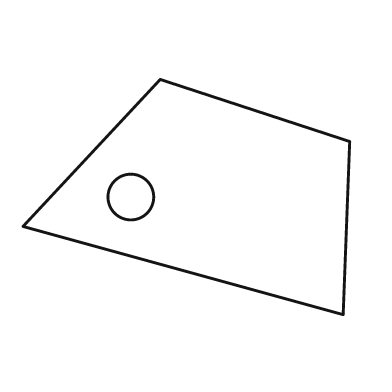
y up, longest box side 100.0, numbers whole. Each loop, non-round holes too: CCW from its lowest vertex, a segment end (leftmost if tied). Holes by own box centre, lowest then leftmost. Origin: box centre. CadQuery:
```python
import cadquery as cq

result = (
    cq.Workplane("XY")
    .moveTo(48.0, -36.0)
    .lineTo(50.0, 17.0)
    .lineTo(-8.0, 36.0)
    .lineTo(-50.0, -9.0)
    .close()
    .moveTo(-17.0, 0.0)
    .circle(7.0)
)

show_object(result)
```